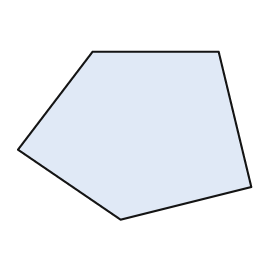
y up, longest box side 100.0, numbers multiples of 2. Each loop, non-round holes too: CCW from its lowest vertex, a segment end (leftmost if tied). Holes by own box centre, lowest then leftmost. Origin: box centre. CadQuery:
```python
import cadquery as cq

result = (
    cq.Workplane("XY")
    .moveTo(-6.0, -36.0)
    .lineTo(50.0, -22.0)
    .lineTo(36.0, 36.0)
    .lineTo(-18.0, 36.0)
    .lineTo(-50.0, -6.0)
    .close()
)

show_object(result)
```